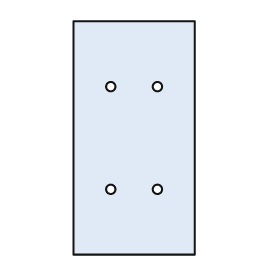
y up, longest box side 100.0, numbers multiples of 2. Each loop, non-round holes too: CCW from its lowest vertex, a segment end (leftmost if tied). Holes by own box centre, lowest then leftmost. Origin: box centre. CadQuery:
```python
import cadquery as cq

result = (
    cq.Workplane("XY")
    .moveTo(-26.0, -50.0)
    .lineTo(26.0, -50.0)
    .lineTo(26.0, 50.0)
    .lineTo(-26.0, 50.0)
    .close()
    .moveTo(-10.0, -22.0)
    .circle(2.0)
    .moveTo(10.0, -22.0)
    .circle(2.0)
    .moveTo(-10.0, 22.0)
    .circle(2.0)
    .moveTo(10.0, 22.0)
    .circle(2.0)
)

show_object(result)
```